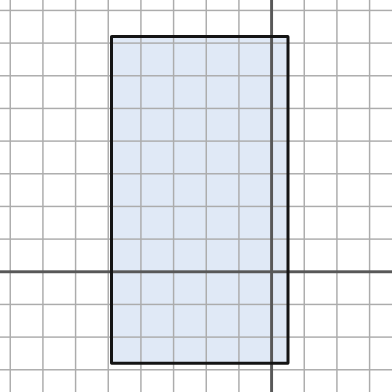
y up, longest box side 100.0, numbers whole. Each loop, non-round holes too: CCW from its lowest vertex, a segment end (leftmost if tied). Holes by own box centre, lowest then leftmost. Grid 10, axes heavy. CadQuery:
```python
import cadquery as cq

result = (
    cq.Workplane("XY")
    .moveTo(-49.0, -28.0)
    .lineTo(5.0, -28.0)
    .lineTo(5.0, 72.0)
    .lineTo(-49.0, 72.0)
    .close()
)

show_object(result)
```